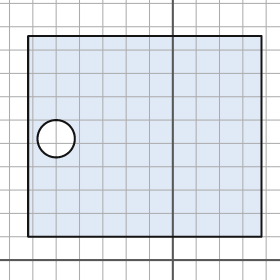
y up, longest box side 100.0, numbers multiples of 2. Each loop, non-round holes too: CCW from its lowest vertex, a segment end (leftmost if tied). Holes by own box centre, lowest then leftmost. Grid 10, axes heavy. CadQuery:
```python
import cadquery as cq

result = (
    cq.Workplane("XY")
    .moveTo(-62.0, 10.0)
    .lineTo(38.0, 10.0)
    .lineTo(38.0, 96.0)
    .lineTo(-62.0, 96.0)
    .close()
    .moveTo(-50.0, 52.0)
    .circle(8.0)
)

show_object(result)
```